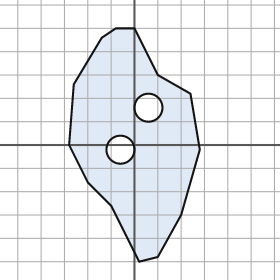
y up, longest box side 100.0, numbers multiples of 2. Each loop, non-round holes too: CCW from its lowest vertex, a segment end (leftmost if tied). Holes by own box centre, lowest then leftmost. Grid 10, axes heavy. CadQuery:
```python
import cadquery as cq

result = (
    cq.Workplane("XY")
    .moveTo(2.0, -50.0)
    .lineTo(10.0, -48.0)
    .lineTo(20.0, -30.0)
    .lineTo(28.0, -2.0)
    .lineTo(24.0, 22.0)
    .lineTo(10.0, 30.0)
    .lineTo(0.0, 50.0)
    .lineTo(-8.0, 50.0)
    .lineTo(-14.0, 46.0)
    .lineTo(-26.0, 26.0)
    .lineTo(-28.0, 0.0)
    .lineTo(-20.0, -16.0)
    .lineTo(-10.0, -26.0)
    .close()
    .moveTo(-6.0, -2.0)
    .circle(6.0)
    .moveTo(6.0, 16.0)
    .circle(6.0)
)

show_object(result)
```